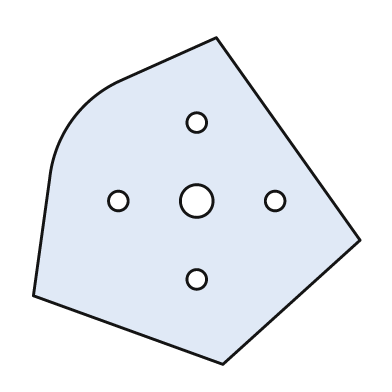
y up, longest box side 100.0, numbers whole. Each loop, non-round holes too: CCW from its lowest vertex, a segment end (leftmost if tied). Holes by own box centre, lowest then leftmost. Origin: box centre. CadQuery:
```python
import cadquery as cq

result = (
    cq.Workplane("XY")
    .moveTo(8.0, -50.0)
    .lineTo(50.0, -12.0)
    .lineTo(6.0, 50.0)
    .lineTo(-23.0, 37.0)
    .threePointArc((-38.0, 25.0), (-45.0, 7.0))
    .lineTo(-50.0, -29.0)
    .close()
    .moveTo(0.0, -24.0)
    .circle(3.0)
    .moveTo(-24.0, 0.0)
    .circle(3.0)
    .moveTo(0.0, 0.0)
    .circle(5.0)
    .moveTo(24.0, 0.0)
    .circle(3.0)
    .moveTo(0.0, 24.0)
    .circle(3.0)
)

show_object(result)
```